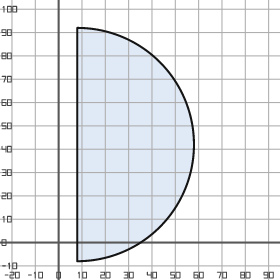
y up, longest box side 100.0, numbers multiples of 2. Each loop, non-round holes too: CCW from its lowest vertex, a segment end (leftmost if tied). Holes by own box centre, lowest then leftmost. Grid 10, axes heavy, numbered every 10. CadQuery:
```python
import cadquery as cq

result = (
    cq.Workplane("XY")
    .moveTo(8.0, -8.0)
    .threePointArc((58.0, 42.0), (8.0, 92.0))
    .close()
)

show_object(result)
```